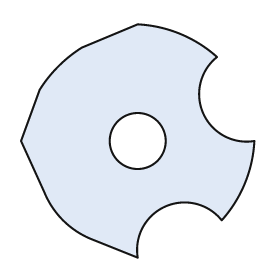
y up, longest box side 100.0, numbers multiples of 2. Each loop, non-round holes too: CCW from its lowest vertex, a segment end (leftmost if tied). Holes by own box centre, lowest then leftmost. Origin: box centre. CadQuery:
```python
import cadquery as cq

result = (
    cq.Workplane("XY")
    .moveTo(0.0, -50.0)
    .threePointArc((12.0, -28.0), (36.0, -34.0))
    .threePointArc((46.0, -18.0), (50.0, 0.0))
    .threePointArc((28.0, 12.0), (34.0, 36.0))
    .threePointArc((18.0, 46.0), (0.0, 50.0))
    .lineTo(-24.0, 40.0)
    .threePointArc((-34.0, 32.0), (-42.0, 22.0))
    .lineTo(-50.0, 0.0)
    .lineTo(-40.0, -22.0)
    .threePointArc((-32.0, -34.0), (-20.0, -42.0))
    .close()
    .moveTo(0.0, 0.0)
    .circle(12.0)
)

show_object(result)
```